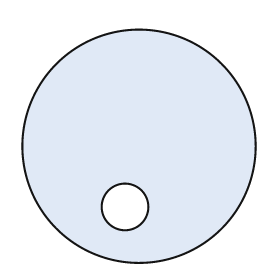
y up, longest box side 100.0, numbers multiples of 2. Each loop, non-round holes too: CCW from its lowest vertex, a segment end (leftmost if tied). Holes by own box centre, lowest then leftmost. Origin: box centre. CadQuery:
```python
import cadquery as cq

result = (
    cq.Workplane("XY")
    .moveTo(0.0, 0.0)
    .circle(50.0)
    .moveTo(-6.0, -26.0)
    .circle(10.0)
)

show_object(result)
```